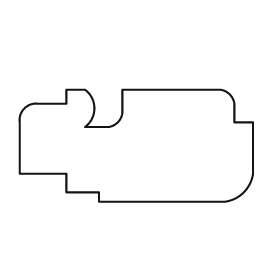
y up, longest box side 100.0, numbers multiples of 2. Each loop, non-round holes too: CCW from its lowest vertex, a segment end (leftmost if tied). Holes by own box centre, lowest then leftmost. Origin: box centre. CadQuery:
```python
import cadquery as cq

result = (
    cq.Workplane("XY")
    .moveTo(-16.0, -24.0)
    .lineTo(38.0, -24.0)
    .threePointArc((46.0, -20.0), (50.0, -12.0))
    .lineTo(50.0, 10.0)
    .lineTo(42.0, 10.0)
    .lineTo(42.0, 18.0)
    .threePointArc((40.0, 22.0), (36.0, 24.0))
    .lineTo(-6.0, 24.0)
    .lineTo(-6.0, 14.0)
    .threePointArc((-8.0, 10.0), (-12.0, 8.0))
    .lineTo(-22.0, 8.0)
    .threePointArc((-18.0, 16.0), (-22.0, 24.0))
    .lineTo(-30.0, 24.0)
    .lineTo(-30.0, 18.0)
    .lineTo(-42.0, 18.0)
    .threePointArc((-48.0, 16.0), (-50.0, 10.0))
    .lineTo(-50.0, -12.0)
    .lineTo(-30.0, -12.0)
    .lineTo(-30.0, -20.0)
    .lineTo(-16.0, -20.0)
    .close()
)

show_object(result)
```